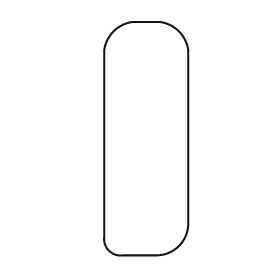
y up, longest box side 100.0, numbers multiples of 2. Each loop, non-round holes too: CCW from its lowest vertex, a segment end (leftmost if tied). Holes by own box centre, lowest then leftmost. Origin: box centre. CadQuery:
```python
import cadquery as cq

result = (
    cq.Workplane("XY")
    .moveTo(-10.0, -50.0)
    .lineTo(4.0, -50.0)
    .threePointArc((14.0, -46.0), (18.0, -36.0))
    .lineTo(18.0, 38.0)
    .threePointArc((14.0, 46.0), (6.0, 50.0))
    .lineTo(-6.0, 50.0)
    .threePointArc((-14.0, 46.0), (-18.0, 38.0))
    .lineTo(-18.0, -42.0)
    .threePointArc((-16.0, -48.0), (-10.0, -50.0))
    .close()
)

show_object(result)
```